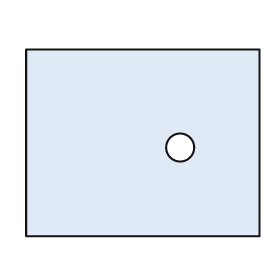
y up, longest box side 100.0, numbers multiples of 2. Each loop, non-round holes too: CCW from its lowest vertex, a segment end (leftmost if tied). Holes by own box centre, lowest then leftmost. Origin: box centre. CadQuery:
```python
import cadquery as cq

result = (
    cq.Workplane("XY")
    .moveTo(-50.0, -40.0)
    .lineTo(50.0, -40.0)
    .lineTo(50.0, 40.0)
    .lineTo(-50.0, 40.0)
    .close()
    .moveTo(16.0, -2.0)
    .circle(6.0)
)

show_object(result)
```